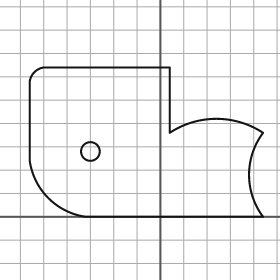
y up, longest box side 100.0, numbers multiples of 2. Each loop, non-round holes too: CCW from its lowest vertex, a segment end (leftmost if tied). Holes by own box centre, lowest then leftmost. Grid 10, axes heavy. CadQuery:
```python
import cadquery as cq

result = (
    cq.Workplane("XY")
    .moveTo(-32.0, 0.0)
    .lineTo(44.0, 0.0)
    .threePointArc((38.0, 18.0), (44.0, 36.0))
    .threePointArc((24.0, 42.0), (4.0, 36.0))
    .lineTo(4.0, 64.0)
    .lineTo(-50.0, 64.0)
    .threePointArc((-54.0, 62.0), (-56.0, 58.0))
    .lineTo(-56.0, 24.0)
    .threePointArc((-48.0, 8.0), (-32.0, 0.0))
    .close()
    .moveTo(-30.0, 28.0)
    .circle(4.0)
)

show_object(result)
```